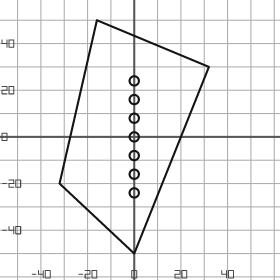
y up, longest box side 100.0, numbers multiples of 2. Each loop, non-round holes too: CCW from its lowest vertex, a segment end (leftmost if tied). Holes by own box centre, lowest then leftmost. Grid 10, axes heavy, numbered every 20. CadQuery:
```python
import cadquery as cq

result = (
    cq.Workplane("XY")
    .moveTo(0.0, -50.0)
    .lineTo(32.0, 30.0)
    .lineTo(-16.0, 50.0)
    .lineTo(-32.0, -20.0)
    .close()
    .moveTo(0.0, -24.0)
    .circle(2.0)
    .moveTo(0.0, -16.0)
    .circle(2.0)
    .moveTo(0.0, -8.0)
    .circle(2.0)
    .moveTo(0.0, 0.0)
    .circle(2.0)
    .moveTo(0.0, 8.0)
    .circle(2.0)
    .moveTo(0.0, 16.0)
    .circle(2.0)
    .moveTo(0.0, 24.0)
    .circle(2.0)
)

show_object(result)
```